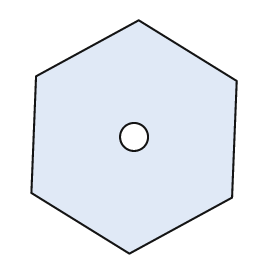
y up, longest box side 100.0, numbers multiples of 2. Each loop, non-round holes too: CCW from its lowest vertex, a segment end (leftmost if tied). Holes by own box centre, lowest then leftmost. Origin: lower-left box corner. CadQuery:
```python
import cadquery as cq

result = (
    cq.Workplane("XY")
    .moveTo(42.0, 0.0)
    .lineTo(86.0, 24.0)
    .lineTo(88.0, 74.0)
    .lineTo(46.0, 100.0)
    .lineTo(2.0, 76.0)
    .lineTo(0.0, 26.0)
    .close()
    .moveTo(44.0, 50.0)
    .circle(6.0)
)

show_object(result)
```